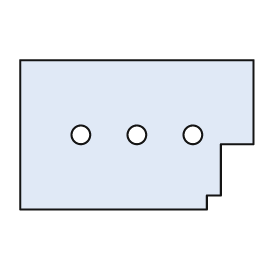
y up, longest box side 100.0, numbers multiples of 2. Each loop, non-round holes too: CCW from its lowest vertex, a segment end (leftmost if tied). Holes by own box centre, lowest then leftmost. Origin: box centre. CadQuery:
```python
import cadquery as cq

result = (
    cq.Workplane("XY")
    .moveTo(-50.0, -32.0)
    .lineTo(30.0, -32.0)
    .lineTo(30.0, -26.0)
    .lineTo(36.0, -26.0)
    .lineTo(36.0, -4.0)
    .lineTo(50.0, -4.0)
    .lineTo(50.0, 32.0)
    .lineTo(-50.0, 32.0)
    .close()
    .moveTo(-24.0, 0.0)
    .circle(4.0)
    .moveTo(0.0, 0.0)
    .circle(4.0)
    .moveTo(24.0, 0.0)
    .circle(4.0)
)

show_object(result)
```